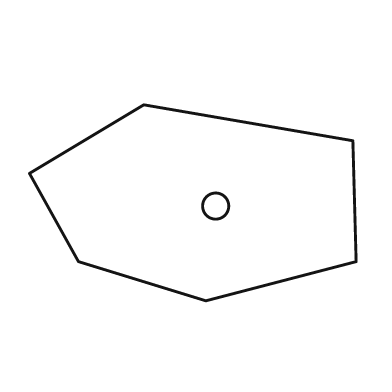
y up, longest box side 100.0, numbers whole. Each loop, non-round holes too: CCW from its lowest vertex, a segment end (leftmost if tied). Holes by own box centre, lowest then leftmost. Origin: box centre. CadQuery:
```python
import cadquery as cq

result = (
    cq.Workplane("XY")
    .moveTo(4.0, -30.0)
    .lineTo(50.0, -18.0)
    .lineTo(49.0, 19.0)
    .lineTo(-15.0, 30.0)
    .lineTo(-50.0, 9.0)
    .lineTo(-35.0, -18.0)
    .close()
    .moveTo(7.0, -1.0)
    .circle(4.0)
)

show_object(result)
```